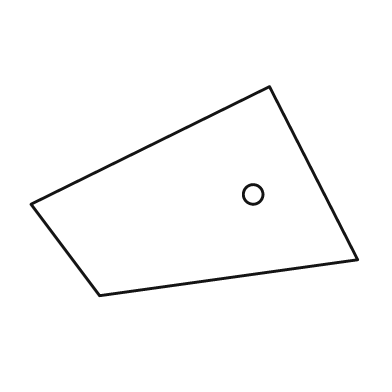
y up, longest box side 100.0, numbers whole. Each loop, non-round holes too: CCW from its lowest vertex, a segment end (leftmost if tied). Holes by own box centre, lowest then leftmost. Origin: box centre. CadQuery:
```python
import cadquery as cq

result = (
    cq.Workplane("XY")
    .moveTo(-29.0, -32.0)
    .lineTo(50.0, -21.0)
    .lineTo(23.0, 32.0)
    .lineTo(-50.0, -4.0)
    .close()
    .moveTo(18.0, -1.0)
    .circle(3.0)
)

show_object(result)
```